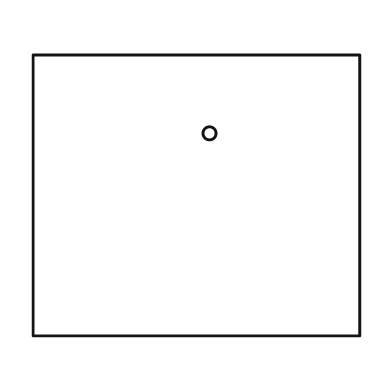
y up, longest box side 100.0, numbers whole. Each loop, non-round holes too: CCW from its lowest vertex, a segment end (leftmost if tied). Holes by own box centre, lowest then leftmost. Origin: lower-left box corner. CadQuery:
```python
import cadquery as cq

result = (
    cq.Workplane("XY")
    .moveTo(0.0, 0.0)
    .lineTo(100.0, 0.0)
    .lineTo(100.0, 86.0)
    .lineTo(0.0, 86.0)
    .close()
    .moveTo(54.0, 62.0)
    .circle(2.0)
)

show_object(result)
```